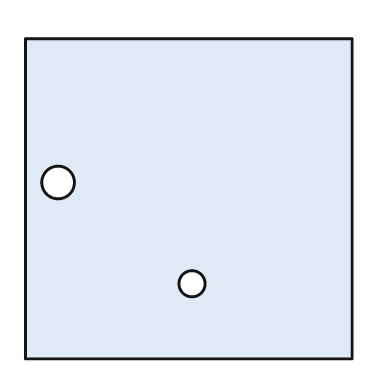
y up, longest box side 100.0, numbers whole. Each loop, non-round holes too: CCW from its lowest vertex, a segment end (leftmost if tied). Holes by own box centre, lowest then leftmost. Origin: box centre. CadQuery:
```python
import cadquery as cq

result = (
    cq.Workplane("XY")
    .moveTo(-50.0, -49.0)
    .lineTo(50.0, -49.0)
    .lineTo(50.0, 49.0)
    .lineTo(-50.0, 49.0)
    .close()
    .moveTo(1.0, -26.0)
    .circle(4.0)
    .moveTo(-40.0, 5.0)
    .circle(5.0)
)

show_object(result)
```